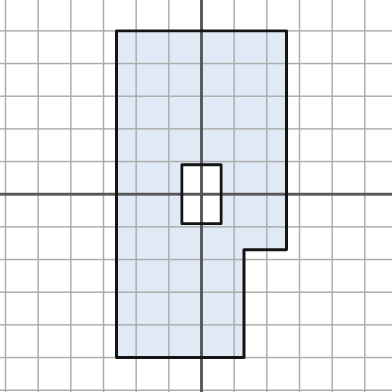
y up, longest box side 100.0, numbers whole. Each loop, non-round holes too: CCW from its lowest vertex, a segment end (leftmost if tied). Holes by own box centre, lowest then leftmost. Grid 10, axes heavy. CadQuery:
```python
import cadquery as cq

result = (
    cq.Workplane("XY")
    .moveTo(-26.0, -50.0)
    .lineTo(13.0, -50.0)
    .lineTo(13.0, -17.0)
    .lineTo(26.0, -17.0)
    .lineTo(26.0, 50.0)
    .lineTo(-26.0, 50.0)
    .close()
    .moveTo(-6.0, -9.0)
    .lineTo(6.0, -9.0)
    .lineTo(6.0, 9.0)
    .lineTo(-6.0, 9.0)
    .close()
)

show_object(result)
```